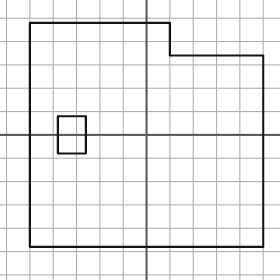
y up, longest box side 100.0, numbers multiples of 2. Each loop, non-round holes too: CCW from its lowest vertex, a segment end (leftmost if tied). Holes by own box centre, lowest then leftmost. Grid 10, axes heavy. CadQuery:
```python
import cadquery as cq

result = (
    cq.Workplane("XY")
    .moveTo(-50.0, -48.0)
    .lineTo(50.0, -48.0)
    .lineTo(50.0, 34.0)
    .lineTo(10.0, 34.0)
    .lineTo(10.0, 48.0)
    .lineTo(-50.0, 48.0)
    .close()
    .moveTo(-38.0, -8.0)
    .lineTo(-26.0, -8.0)
    .lineTo(-26.0, 8.0)
    .lineTo(-38.0, 8.0)
    .close()
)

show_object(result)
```